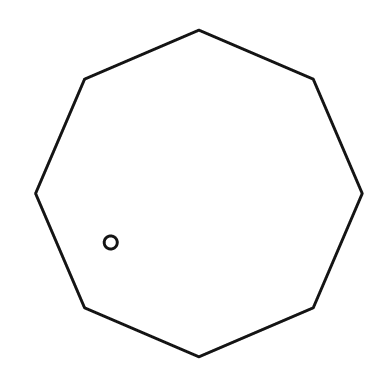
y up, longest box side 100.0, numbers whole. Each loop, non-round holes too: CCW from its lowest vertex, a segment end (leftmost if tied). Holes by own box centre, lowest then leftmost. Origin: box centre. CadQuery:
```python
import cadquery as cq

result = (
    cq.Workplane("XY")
    .moveTo(0.0, -50.0)
    .lineTo(35.0, -35.0)
    .lineTo(50.0, 0.0)
    .lineTo(35.0, 35.0)
    .lineTo(0.0, 50.0)
    .lineTo(-35.0, 35.0)
    .lineTo(-50.0, 0.0)
    .lineTo(-35.0, -35.0)
    .close()
    .moveTo(-27.0, -15.0)
    .circle(2.0)
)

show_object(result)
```